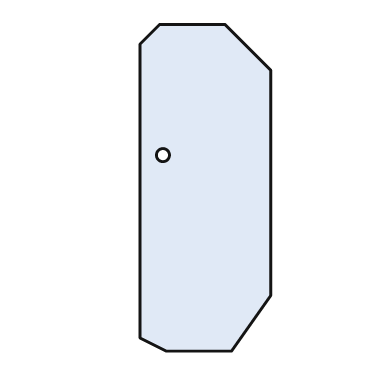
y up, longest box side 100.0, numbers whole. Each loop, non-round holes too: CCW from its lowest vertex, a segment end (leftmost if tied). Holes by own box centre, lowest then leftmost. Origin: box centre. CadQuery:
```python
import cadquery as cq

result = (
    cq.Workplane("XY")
    .moveTo(-12.0, -50.0)
    .lineTo(8.0, -50.0)
    .lineTo(20.0, -33.0)
    .lineTo(20.0, 36.0)
    .lineTo(6.0, 50.0)
    .lineTo(-14.0, 50.0)
    .lineTo(-20.0, 44.0)
    .lineTo(-20.0, -46.0)
    .close()
    .moveTo(-13.0, 10.0)
    .circle(2.0)
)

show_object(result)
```